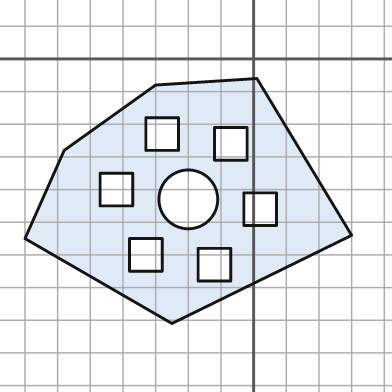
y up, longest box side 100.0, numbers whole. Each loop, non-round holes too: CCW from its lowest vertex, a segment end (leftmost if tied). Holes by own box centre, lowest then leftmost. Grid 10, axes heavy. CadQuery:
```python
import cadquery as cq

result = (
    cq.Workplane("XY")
    .moveTo(-25.0, -81.0)
    .lineTo(30.0, -54.0)
    .lineTo(1.0, -6.0)
    .lineTo(-30.0, -8.0)
    .lineTo(-58.0, -28.0)
    .lineTo(-70.0, -55.0)
    .close()
    .moveTo(-17.0, -68.0)
    .lineTo(-7.0, -68.0)
    .lineTo(-7.0, -58.0)
    .lineTo(-17.0, -58.0)
    .close()
    .moveTo(-38.0, -65.0)
    .lineTo(-28.0, -65.0)
    .lineTo(-28.0, -55.0)
    .lineTo(-38.0, -55.0)
    .close()
    .moveTo(-3.0, -51.0)
    .lineTo(7.0, -51.0)
    .lineTo(7.0, -41.0)
    .lineTo(-3.0, -41.0)
    .close()
    .moveTo(-20.0, -43.0)
    .circle(9.0)
    .moveTo(-47.0, -45.0)
    .lineTo(-37.0, -45.0)
    .lineTo(-37.0, -35.0)
    .lineTo(-47.0, -35.0)
    .close()
    .moveTo(-12.0, -31.0)
    .lineTo(-2.0, -31.0)
    .lineTo(-2.0, -21.0)
    .lineTo(-12.0, -21.0)
    .close()
    .moveTo(-33.0, -28.0)
    .lineTo(-23.0, -28.0)
    .lineTo(-23.0, -18.0)
    .lineTo(-33.0, -18.0)
    .close()
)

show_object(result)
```